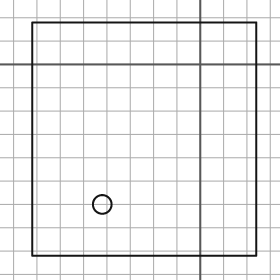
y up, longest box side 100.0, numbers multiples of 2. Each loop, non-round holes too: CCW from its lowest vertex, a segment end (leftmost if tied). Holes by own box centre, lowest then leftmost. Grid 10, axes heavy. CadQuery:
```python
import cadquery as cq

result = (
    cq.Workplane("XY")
    .moveTo(-72.0, -82.0)
    .lineTo(24.0, -82.0)
    .lineTo(24.0, 18.0)
    .lineTo(-72.0, 18.0)
    .close()
    .moveTo(-42.0, -60.0)
    .circle(4.0)
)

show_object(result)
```